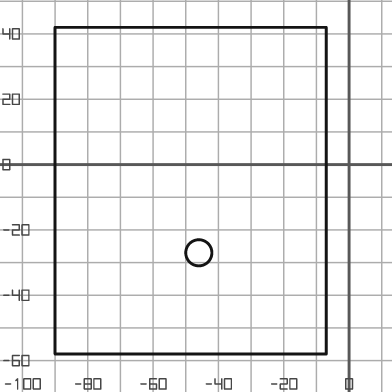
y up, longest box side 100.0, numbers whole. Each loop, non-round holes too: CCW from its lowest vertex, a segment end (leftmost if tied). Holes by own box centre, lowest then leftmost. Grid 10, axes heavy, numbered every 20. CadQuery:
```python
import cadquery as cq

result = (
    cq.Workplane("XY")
    .moveTo(-90.0, -58.0)
    .lineTo(-7.0, -58.0)
    .lineTo(-7.0, 42.0)
    .lineTo(-90.0, 42.0)
    .close()
    .moveTo(-46.0, -27.0)
    .circle(4.0)
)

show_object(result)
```